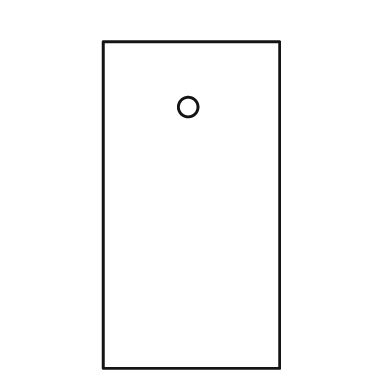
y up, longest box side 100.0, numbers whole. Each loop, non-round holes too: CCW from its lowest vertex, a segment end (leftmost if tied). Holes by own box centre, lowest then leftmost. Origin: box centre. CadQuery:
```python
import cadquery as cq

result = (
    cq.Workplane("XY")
    .moveTo(-27.0, -50.0)
    .lineTo(27.0, -50.0)
    .lineTo(27.0, 50.0)
    .lineTo(-27.0, 50.0)
    .close()
    .moveTo(-1.0, 30.0)
    .circle(3.0)
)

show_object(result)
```